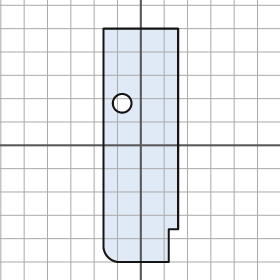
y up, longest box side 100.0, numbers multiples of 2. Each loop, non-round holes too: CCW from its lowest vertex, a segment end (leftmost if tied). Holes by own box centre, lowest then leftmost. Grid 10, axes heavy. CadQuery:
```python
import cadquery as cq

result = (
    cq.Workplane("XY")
    .moveTo(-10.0, -50.0)
    .lineTo(12.0, -50.0)
    .lineTo(12.0, -36.0)
    .lineTo(16.0, -36.0)
    .lineTo(16.0, 50.0)
    .lineTo(-16.0, 50.0)
    .lineTo(-16.0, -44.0)
    .threePointArc((-14.0, -48.0), (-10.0, -50.0))
    .close()
    .moveTo(-8.0, 18.0)
    .circle(4.0)
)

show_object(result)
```